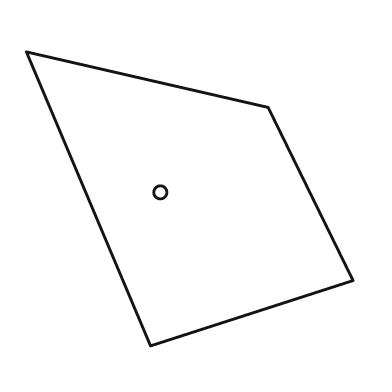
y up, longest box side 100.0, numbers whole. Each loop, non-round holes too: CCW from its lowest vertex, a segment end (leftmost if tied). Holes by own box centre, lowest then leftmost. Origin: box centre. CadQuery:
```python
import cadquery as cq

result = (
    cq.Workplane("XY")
    .moveTo(-12.0, -45.0)
    .lineTo(50.0, -25.0)
    .lineTo(24.0, 28.0)
    .lineTo(-50.0, 45.0)
    .close()
    .moveTo(-9.0, 2.0)
    .circle(2.0)
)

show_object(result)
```